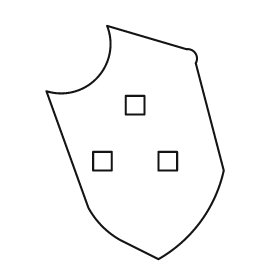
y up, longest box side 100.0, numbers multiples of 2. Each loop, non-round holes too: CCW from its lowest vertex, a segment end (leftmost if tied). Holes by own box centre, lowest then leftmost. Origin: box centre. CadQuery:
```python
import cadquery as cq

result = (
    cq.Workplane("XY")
    .moveTo(10.0, -50.0)
    .threePointArc((28.0, -34.0), (38.0, -12.0))
    .lineTo(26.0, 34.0)
    .threePointArc((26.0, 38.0), (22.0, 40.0))
    .lineTo(-12.0, 50.0)
    .threePointArc((-16.0, 28.0), (-38.0, 22.0))
    .lineTo(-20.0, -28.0)
    .threePointArc((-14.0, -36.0), (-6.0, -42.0))
    .close()
    .moveTo(-18.0, -12.0)
    .lineTo(-10.0, -12.0)
    .lineTo(-10.0, -4.0)
    .lineTo(-18.0, -4.0)
    .close()
    .moveTo(10.0, -12.0)
    .lineTo(18.0, -12.0)
    .lineTo(18.0, -4.0)
    .lineTo(10.0, -4.0)
    .close()
    .moveTo(-4.0, 12.0)
    .lineTo(4.0, 12.0)
    .lineTo(4.0, 20.0)
    .lineTo(-4.0, 20.0)
    .close()
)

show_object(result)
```